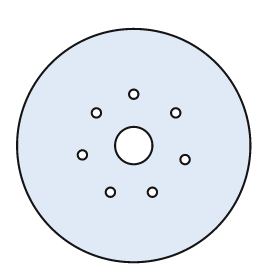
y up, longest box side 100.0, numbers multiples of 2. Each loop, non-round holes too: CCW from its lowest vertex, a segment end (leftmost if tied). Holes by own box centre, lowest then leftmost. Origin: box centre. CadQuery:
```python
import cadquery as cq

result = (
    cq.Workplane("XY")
    .moveTo(0.0, 0.0)
    .circle(50.0)
    .moveTo(-10.0, -20.0)
    .circle(2.0)
    .moveTo(8.0, -20.0)
    .circle(2.0)
    .moveTo(22.0, -6.0)
    .circle(2.0)
    .moveTo(-22.0, -4.0)
    .circle(2.0)
    .moveTo(0.0, 0.0)
    .circle(8.0)
    .moveTo(-16.0, 14.0)
    .circle(2.0)
    .moveTo(18.0, 14.0)
    .circle(2.0)
    .moveTo(0.0, 22.0)
    .circle(2.0)
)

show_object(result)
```